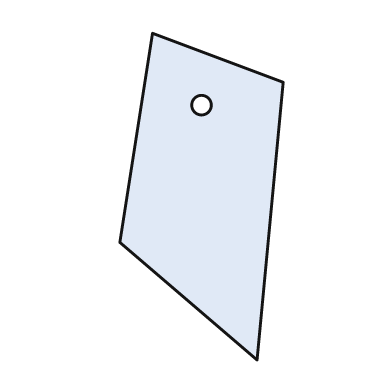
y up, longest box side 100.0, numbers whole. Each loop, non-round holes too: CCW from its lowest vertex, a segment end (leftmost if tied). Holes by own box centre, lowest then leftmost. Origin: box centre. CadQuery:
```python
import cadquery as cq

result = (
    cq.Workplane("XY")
    .moveTo(17.0, -50.0)
    .lineTo(25.0, 35.0)
    .lineTo(-15.0, 50.0)
    .lineTo(-25.0, -14.0)
    .close()
    .moveTo(0.0, 28.0)
    .circle(3.0)
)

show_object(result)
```